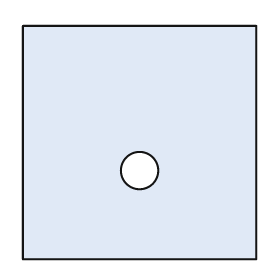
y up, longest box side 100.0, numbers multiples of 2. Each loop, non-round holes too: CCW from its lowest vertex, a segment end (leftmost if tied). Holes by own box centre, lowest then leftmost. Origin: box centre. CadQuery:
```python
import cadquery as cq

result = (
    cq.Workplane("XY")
    .moveTo(-50.0, -50.0)
    .lineTo(50.0, -50.0)
    .lineTo(50.0, 50.0)
    .lineTo(-50.0, 50.0)
    .close()
    .moveTo(0.0, -12.0)
    .circle(8.0)
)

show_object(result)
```